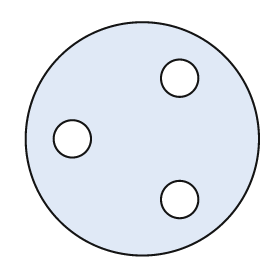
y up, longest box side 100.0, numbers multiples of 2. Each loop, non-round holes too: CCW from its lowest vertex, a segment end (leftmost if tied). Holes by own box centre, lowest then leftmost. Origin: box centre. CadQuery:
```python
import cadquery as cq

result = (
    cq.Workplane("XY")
    .moveTo(0.0, 0.0)
    .circle(50.0)
    .moveTo(16.0, -26.0)
    .circle(8.0)
    .moveTo(-30.0, 0.0)
    .circle(8.0)
    .moveTo(16.0, 26.0)
    .circle(8.0)
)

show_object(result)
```